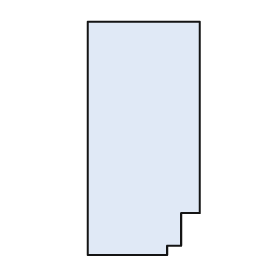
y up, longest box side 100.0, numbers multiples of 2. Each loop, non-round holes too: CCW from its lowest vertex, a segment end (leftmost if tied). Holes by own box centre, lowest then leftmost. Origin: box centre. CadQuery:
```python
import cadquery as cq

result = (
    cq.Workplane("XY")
    .moveTo(-24.0, -50.0)
    .lineTo(10.0, -50.0)
    .lineTo(10.0, -46.0)
    .lineTo(16.0, -46.0)
    .lineTo(16.0, -32.0)
    .lineTo(24.0, -32.0)
    .lineTo(24.0, 50.0)
    .lineTo(-24.0, 50.0)
    .close()
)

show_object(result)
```